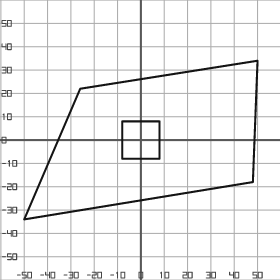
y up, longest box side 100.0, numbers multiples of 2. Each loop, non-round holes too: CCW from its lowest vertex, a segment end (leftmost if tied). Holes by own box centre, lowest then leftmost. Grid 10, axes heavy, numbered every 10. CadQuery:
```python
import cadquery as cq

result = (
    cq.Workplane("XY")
    .moveTo(-50.0, -34.0)
    .lineTo(48.0, -18.0)
    .lineTo(50.0, 34.0)
    .lineTo(-26.0, 22.0)
    .close()
    .moveTo(-8.0, -8.0)
    .lineTo(8.0, -8.0)
    .lineTo(8.0, 8.0)
    .lineTo(-8.0, 8.0)
    .close()
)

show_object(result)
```